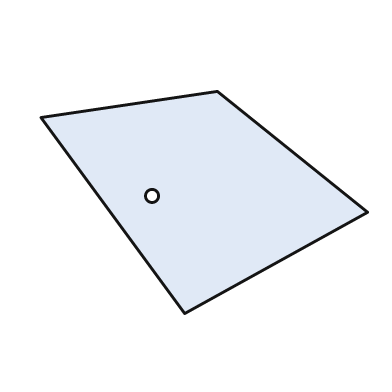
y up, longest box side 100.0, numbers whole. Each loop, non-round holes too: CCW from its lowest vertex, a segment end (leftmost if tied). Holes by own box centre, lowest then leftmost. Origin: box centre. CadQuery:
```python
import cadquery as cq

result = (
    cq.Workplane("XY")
    .moveTo(-6.0, -34.0)
    .lineTo(50.0, -3.0)
    .lineTo(4.0, 34.0)
    .lineTo(-50.0, 26.0)
    .close()
    .moveTo(-16.0, 2.0)
    .circle(2.0)
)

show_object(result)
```